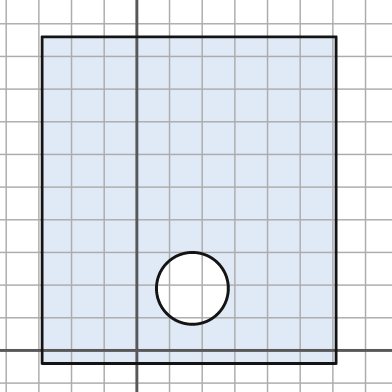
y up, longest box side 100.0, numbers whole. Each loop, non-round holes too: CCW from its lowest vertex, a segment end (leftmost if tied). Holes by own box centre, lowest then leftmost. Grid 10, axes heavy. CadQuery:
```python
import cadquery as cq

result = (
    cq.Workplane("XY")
    .moveTo(-29.0, -4.0)
    .lineTo(61.0, -4.0)
    .lineTo(61.0, 96.0)
    .lineTo(-29.0, 96.0)
    .close()
    .moveTo(17.0, 19.0)
    .circle(11.0)
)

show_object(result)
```